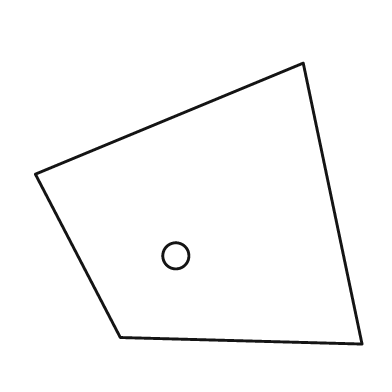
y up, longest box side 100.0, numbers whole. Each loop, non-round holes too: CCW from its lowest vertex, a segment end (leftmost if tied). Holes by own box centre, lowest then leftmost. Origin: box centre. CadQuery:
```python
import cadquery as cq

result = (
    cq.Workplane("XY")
    .moveTo(50.0, -43.0)
    .lineTo(32.0, 43.0)
    .lineTo(-50.0, 9.0)
    .lineTo(-24.0, -41.0)
    .close()
    .moveTo(-7.0, -16.0)
    .circle(4.0)
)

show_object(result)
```